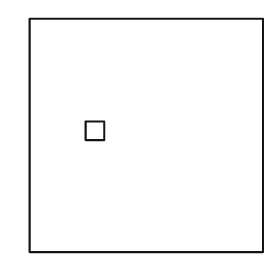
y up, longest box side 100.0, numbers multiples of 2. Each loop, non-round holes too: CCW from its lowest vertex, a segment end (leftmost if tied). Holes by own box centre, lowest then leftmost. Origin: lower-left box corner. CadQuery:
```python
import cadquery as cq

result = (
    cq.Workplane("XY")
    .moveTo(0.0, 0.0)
    .lineTo(100.0, 0.0)
    .lineTo(100.0, 100.0)
    .lineTo(0.0, 100.0)
    .close()
    .moveTo(24.0, 48.0)
    .lineTo(32.0, 48.0)
    .lineTo(32.0, 56.0)
    .lineTo(24.0, 56.0)
    .close()
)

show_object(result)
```